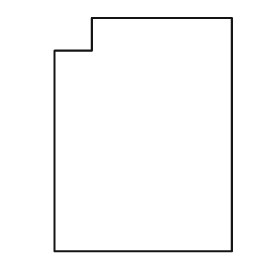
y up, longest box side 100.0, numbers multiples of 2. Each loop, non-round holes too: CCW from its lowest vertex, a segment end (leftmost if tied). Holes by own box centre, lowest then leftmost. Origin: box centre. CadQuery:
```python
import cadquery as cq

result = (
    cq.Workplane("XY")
    .moveTo(-38.0, -50.0)
    .lineTo(38.0, -50.0)
    .lineTo(38.0, 50.0)
    .lineTo(-22.0, 50.0)
    .lineTo(-22.0, 36.0)
    .lineTo(-38.0, 36.0)
    .close()
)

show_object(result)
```